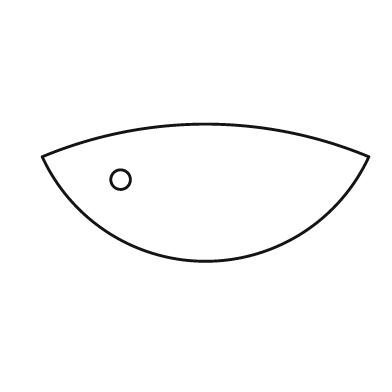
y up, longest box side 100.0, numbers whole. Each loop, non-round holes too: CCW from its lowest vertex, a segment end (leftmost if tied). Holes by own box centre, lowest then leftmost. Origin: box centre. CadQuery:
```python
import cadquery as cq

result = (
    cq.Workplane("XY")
    .moveTo(-50.0, 11.0)
    .threePointArc((0.0, -21.0), (50.0, 11.0))
    .threePointArc((0.0, 21.0), (-50.0, 11.0))
    .close()
    .moveTo(-26.0, 4.0)
    .circle(3.0)
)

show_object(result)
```